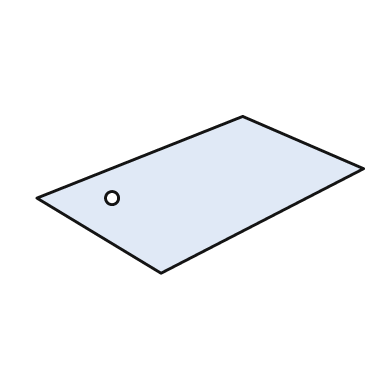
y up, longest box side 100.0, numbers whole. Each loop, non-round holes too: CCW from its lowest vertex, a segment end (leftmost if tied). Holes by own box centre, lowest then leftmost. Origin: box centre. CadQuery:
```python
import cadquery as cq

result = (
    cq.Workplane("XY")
    .moveTo(-12.0, -24.0)
    .lineTo(50.0, 8.0)
    .lineTo(13.0, 24.0)
    .lineTo(-50.0, -1.0)
    .close()
    .moveTo(-27.0, -1.0)
    .circle(2.0)
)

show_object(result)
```